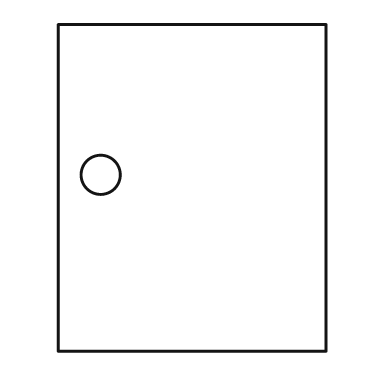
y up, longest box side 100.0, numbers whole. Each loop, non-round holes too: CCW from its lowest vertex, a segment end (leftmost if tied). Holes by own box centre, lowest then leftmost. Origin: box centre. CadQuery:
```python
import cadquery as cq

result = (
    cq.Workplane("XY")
    .moveTo(-41.0, -50.0)
    .lineTo(41.0, -50.0)
    .lineTo(41.0, 50.0)
    .lineTo(-41.0, 50.0)
    .close()
    .moveTo(-28.0, 4.0)
    .circle(6.0)
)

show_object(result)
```